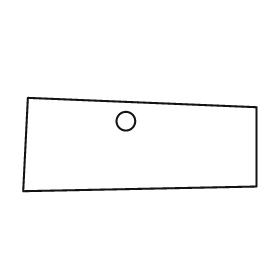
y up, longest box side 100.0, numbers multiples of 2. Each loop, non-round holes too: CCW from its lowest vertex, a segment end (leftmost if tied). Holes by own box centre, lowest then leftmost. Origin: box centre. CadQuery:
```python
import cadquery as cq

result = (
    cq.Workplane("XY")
    .moveTo(-50.0, -20.0)
    .lineTo(50.0, -18.0)
    .lineTo(50.0, 16.0)
    .lineTo(-48.0, 20.0)
    .close()
    .moveTo(-6.0, 10.0)
    .circle(4.0)
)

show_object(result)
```